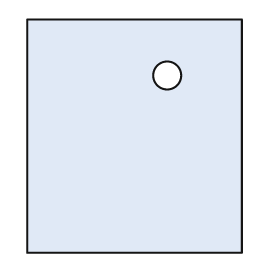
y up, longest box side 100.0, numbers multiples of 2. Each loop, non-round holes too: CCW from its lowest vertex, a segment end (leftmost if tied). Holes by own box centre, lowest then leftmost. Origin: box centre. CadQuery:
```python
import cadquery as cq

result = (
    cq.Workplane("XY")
    .moveTo(-46.0, -50.0)
    .lineTo(46.0, -50.0)
    .lineTo(46.0, 50.0)
    .lineTo(-46.0, 50.0)
    .close()
    .moveTo(14.0, 26.0)
    .circle(6.0)
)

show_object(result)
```